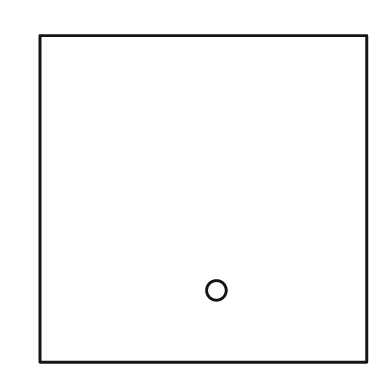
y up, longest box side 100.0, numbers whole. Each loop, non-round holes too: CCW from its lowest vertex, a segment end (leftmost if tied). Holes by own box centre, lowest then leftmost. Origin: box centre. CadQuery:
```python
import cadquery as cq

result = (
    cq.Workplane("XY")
    .moveTo(-50.0, -50.0)
    .lineTo(50.0, -50.0)
    .lineTo(50.0, 50.0)
    .lineTo(-50.0, 50.0)
    .close()
    .moveTo(4.0, -28.0)
    .circle(3.0)
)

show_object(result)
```